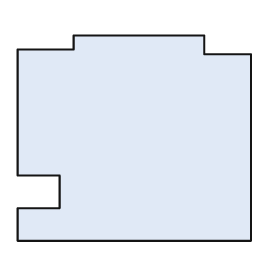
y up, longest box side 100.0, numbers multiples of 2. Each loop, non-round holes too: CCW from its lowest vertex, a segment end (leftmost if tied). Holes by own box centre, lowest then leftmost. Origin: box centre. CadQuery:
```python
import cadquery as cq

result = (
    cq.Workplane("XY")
    .moveTo(-50.0, -44.0)
    .lineTo(50.0, -44.0)
    .lineTo(50.0, 36.0)
    .lineTo(30.0, 36.0)
    .lineTo(30.0, 44.0)
    .lineTo(-26.0, 44.0)
    .lineTo(-26.0, 38.0)
    .lineTo(-50.0, 38.0)
    .lineTo(-50.0, -16.0)
    .lineTo(-32.0, -16.0)
    .lineTo(-32.0, -30.0)
    .lineTo(-50.0, -30.0)
    .close()
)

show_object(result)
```